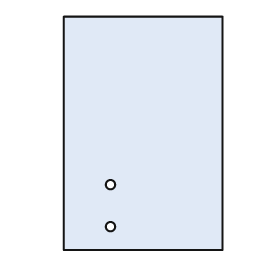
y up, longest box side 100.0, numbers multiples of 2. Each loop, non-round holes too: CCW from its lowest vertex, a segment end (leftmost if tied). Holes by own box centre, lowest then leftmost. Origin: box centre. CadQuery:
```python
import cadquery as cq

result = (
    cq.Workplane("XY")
    .moveTo(-34.0, -50.0)
    .lineTo(34.0, -50.0)
    .lineTo(34.0, 50.0)
    .lineTo(-34.0, 50.0)
    .close()
    .moveTo(-14.0, -40.0)
    .circle(2.0)
    .moveTo(-14.0, -22.0)
    .circle(2.0)
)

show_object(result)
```